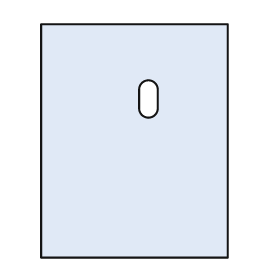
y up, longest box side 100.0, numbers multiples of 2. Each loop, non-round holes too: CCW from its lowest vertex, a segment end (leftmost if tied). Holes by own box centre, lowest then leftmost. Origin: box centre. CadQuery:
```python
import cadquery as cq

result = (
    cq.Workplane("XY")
    .moveTo(-40.0, -50.0)
    .lineTo(40.0, -50.0)
    .lineTo(40.0, 50.0)
    .lineTo(-40.0, 50.0)
    .close()
    .moveTo(2.0, 14.0)
    .threePointArc((6.0, 10.0), (10.0, 14.0))
    .lineTo(10.0, 22.0)
    .threePointArc((6.0, 26.0), (2.0, 22.0))
    .close()
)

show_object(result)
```